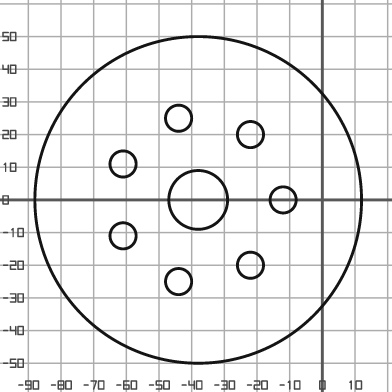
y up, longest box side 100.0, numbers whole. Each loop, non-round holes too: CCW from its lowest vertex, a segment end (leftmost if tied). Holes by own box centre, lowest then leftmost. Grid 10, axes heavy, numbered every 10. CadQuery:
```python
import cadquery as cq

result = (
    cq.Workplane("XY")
    .moveTo(-38.0, 0.0)
    .circle(50.0)
    .moveTo(-44.0, -25.0)
    .circle(4.0)
    .moveTo(-22.0, -20.0)
    .circle(4.0)
    .moveTo(-61.0, -11.0)
    .circle(4.0)
    .moveTo(-38.0, 0.0)
    .circle(9.0)
    .moveTo(-12.0, 0.0)
    .circle(4.0)
    .moveTo(-61.0, 11.0)
    .circle(4.0)
    .moveTo(-22.0, 20.0)
    .circle(4.0)
    .moveTo(-44.0, 25.0)
    .circle(4.0)
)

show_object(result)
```